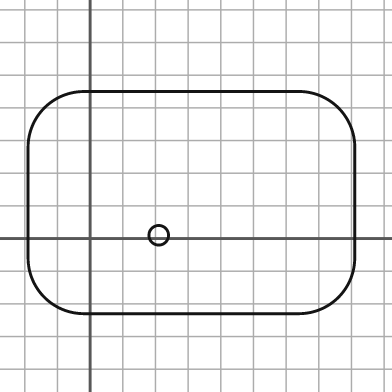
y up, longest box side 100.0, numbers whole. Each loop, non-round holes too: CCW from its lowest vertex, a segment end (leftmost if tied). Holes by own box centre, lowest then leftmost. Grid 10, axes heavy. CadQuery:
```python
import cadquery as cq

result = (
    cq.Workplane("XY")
    .moveTo(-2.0, -23.0)
    .lineTo(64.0, -23.0)
    .threePointArc((76.0, -18.0), (81.0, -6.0))
    .lineTo(81.0, 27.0)
    .threePointArc((76.0, 40.0), (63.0, 45.0))
    .lineTo(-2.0, 45.0)
    .threePointArc((-14.0, 40.0), (-19.0, 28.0))
    .lineTo(-19.0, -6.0)
    .threePointArc((-14.0, -18.0), (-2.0, -23.0))
    .close()
    .moveTo(21.0, 1.0)
    .circle(3.0)
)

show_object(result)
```